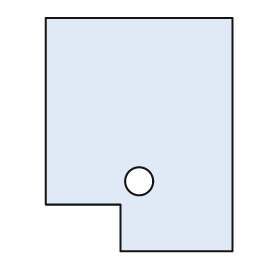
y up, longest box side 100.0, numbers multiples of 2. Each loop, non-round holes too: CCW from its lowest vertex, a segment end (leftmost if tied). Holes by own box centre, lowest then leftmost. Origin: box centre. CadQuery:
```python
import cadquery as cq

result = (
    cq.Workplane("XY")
    .moveTo(-8.0, -50.0)
    .lineTo(40.0, -50.0)
    .lineTo(40.0, 50.0)
    .lineTo(-40.0, 50.0)
    .lineTo(-40.0, -30.0)
    .lineTo(-8.0, -30.0)
    .close()
    .moveTo(0.0, -20.0)
    .circle(6.0)
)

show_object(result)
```